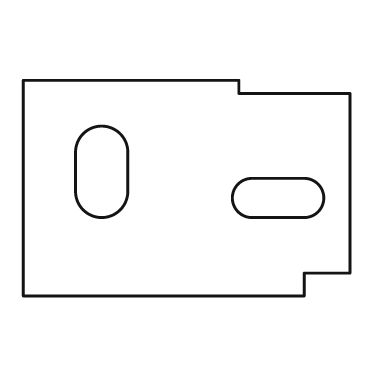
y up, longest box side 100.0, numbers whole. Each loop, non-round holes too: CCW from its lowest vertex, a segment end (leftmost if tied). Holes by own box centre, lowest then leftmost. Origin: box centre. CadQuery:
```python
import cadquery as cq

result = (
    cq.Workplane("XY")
    .moveTo(-50.0, -33.0)
    .lineTo(36.0, -33.0)
    .lineTo(36.0, -26.0)
    .lineTo(50.0, -26.0)
    .lineTo(50.0, 29.0)
    .lineTo(16.0, 29.0)
    .lineTo(16.0, 33.0)
    .lineTo(-50.0, 33.0)
    .close()
    .moveTo(20.0, -9.0)
    .lineTo(36.0, -9.0)
    .threePointArc((42.0, -3.0), (36.0, 3.0))
    .lineTo(20.0, 3.0)
    .threePointArc((14.0, -3.0), (20.0, -9.0))
    .close()
    .moveTo(-34.0, -1.0)
    .threePointArc((-26.0, -9.0), (-18.0, -1.0))
    .lineTo(-18.0, 11.0)
    .threePointArc((-26.0, 19.0), (-34.0, 11.0))
    .close()
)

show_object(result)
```